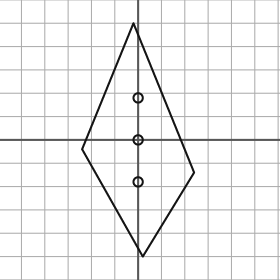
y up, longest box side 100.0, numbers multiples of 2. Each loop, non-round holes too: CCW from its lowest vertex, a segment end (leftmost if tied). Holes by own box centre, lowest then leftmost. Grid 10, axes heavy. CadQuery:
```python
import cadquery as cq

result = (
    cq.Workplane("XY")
    .moveTo(2.0, -50.0)
    .lineTo(24.0, -14.0)
    .lineTo(-2.0, 50.0)
    .lineTo(-24.0, -4.0)
    .close()
    .moveTo(0.0, -18.0)
    .circle(2.0)
    .moveTo(0.0, 0.0)
    .circle(2.0)
    .moveTo(0.0, 18.0)
    .circle(2.0)
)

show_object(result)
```